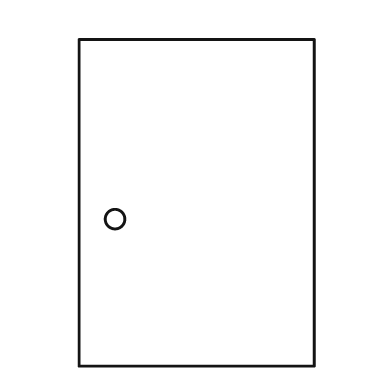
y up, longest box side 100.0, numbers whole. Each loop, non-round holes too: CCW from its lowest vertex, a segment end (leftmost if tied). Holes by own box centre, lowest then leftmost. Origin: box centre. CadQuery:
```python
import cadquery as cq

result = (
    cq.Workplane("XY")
    .moveTo(-36.0, -50.0)
    .lineTo(36.0, -50.0)
    .lineTo(36.0, 50.0)
    .lineTo(-36.0, 50.0)
    .close()
    .moveTo(-25.0, -5.0)
    .circle(3.0)
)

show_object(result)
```